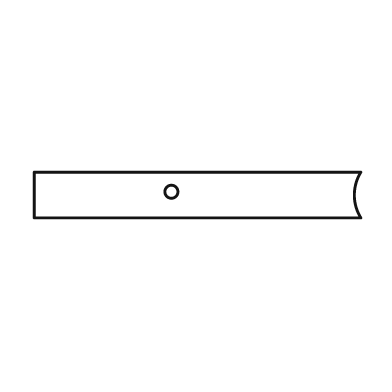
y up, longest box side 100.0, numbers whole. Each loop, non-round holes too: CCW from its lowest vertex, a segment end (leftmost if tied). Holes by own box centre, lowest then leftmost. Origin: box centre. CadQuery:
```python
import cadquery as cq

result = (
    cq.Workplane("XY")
    .moveTo(-50.0, -7.0)
    .lineTo(50.0, -7.0)
    .threePointArc((48.0, 0.0), (50.0, 7.0))
    .lineTo(-50.0, 7.0)
    .close()
    .moveTo(-8.0, 1.0)
    .circle(2.0)
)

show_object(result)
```